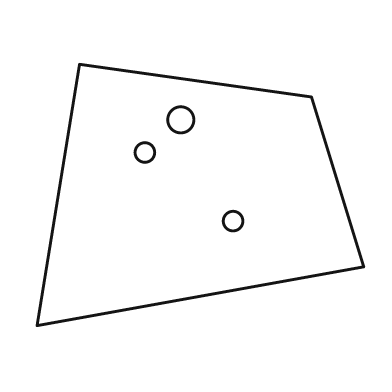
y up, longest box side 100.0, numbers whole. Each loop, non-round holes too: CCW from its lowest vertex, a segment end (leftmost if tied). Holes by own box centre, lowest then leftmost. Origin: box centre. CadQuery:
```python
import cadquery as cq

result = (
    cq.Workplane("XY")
    .moveTo(-50.0, -40.0)
    .lineTo(50.0, -22.0)
    .lineTo(34.0, 30.0)
    .lineTo(-37.0, 40.0)
    .close()
    .moveTo(10.0, -8.0)
    .circle(3.0)
    .moveTo(-17.0, 13.0)
    .circle(3.0)
    .moveTo(-6.0, 23.0)
    .circle(4.0)
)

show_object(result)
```